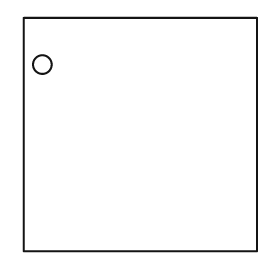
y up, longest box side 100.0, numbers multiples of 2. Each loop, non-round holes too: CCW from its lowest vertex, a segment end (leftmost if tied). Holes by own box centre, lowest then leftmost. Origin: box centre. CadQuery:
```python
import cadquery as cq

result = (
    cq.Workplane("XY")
    .moveTo(-50.0, -50.0)
    .lineTo(50.0, -50.0)
    .lineTo(50.0, 50.0)
    .lineTo(-50.0, 50.0)
    .close()
    .moveTo(-42.0, 30.0)
    .circle(4.0)
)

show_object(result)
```